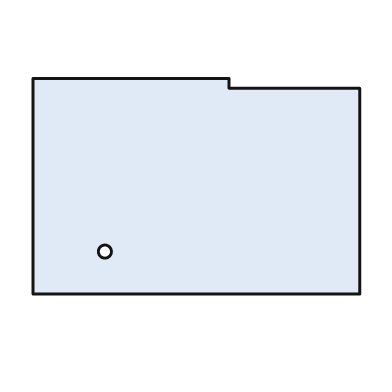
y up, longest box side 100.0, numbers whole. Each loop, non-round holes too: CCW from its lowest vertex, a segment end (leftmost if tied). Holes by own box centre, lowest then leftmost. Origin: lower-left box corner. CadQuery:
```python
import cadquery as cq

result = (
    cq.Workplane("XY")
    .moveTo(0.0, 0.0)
    .lineTo(100.0, 0.0)
    .lineTo(100.0, 63.0)
    .lineTo(60.0, 63.0)
    .lineTo(60.0, 66.0)
    .lineTo(0.0, 66.0)
    .close()
    .moveTo(22.0, 13.0)
    .circle(2.0)
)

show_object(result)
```